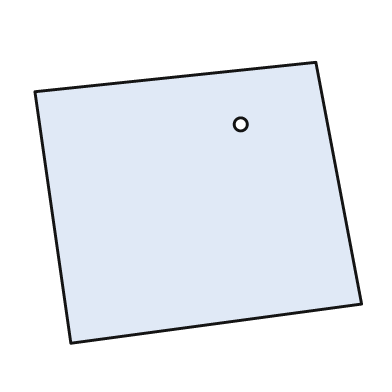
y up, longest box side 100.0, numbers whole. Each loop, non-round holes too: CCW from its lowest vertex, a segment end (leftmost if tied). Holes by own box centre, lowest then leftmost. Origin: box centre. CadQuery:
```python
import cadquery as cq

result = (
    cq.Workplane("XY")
    .moveTo(-39.0, -43.0)
    .lineTo(50.0, -31.0)
    .lineTo(36.0, 43.0)
    .lineTo(-50.0, 34.0)
    .close()
    .moveTo(13.0, 24.0)
    .circle(2.0)
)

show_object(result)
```